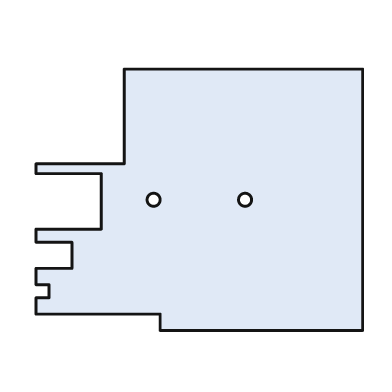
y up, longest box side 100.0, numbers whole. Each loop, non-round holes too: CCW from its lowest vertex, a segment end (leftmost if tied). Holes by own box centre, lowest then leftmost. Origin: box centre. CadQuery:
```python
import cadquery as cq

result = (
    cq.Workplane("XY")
    .moveTo(-12.0, -40.0)
    .lineTo(50.0, -40.0)
    .lineTo(50.0, 40.0)
    .lineTo(-23.0, 40.0)
    .lineTo(-23.0, 11.0)
    .lineTo(-50.0, 11.0)
    .lineTo(-50.0, 8.0)
    .lineTo(-30.0, 8.0)
    .lineTo(-30.0, -9.0)
    .lineTo(-50.0, -9.0)
    .lineTo(-50.0, -13.0)
    .lineTo(-39.0, -13.0)
    .lineTo(-39.0, -21.0)
    .lineTo(-50.0, -21.0)
    .lineTo(-50.0, -26.0)
    .lineTo(-46.0, -26.0)
    .lineTo(-46.0, -30.0)
    .lineTo(-50.0, -30.0)
    .lineTo(-50.0, -35.0)
    .lineTo(-12.0, -35.0)
    .close()
    .moveTo(-14.0, 0.0)
    .circle(2.0)
    .moveTo(14.0, 0.0)
    .circle(2.0)
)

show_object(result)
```